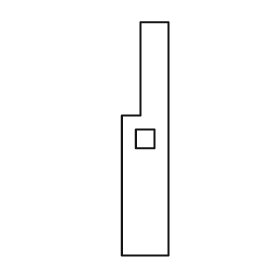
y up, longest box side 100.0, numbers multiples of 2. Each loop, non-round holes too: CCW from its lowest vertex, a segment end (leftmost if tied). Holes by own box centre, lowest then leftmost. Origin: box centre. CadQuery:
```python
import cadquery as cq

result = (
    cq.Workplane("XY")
    .moveTo(-10.0, -50.0)
    .lineTo(10.0, -50.0)
    .lineTo(10.0, 50.0)
    .lineTo(-2.0, 50.0)
    .lineTo(-2.0, 10.0)
    .lineTo(-10.0, 10.0)
    .close()
    .moveTo(-4.0, -4.0)
    .lineTo(4.0, -4.0)
    .lineTo(4.0, 4.0)
    .lineTo(-4.0, 4.0)
    .close()
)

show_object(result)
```